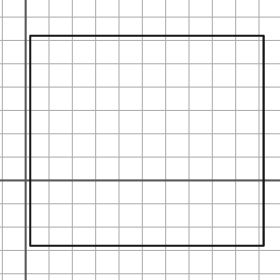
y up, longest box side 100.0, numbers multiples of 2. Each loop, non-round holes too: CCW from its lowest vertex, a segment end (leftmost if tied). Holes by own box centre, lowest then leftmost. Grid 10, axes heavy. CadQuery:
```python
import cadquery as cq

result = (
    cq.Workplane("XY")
    .moveTo(2.0, -28.0)
    .lineTo(102.0, -28.0)
    .lineTo(102.0, 62.0)
    .lineTo(2.0, 62.0)
    .close()
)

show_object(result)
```